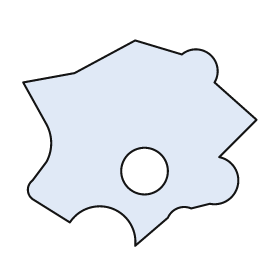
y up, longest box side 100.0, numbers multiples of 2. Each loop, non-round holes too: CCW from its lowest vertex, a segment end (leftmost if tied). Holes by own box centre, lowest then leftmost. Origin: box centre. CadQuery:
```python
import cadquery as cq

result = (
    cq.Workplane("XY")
    .moveTo(-2.0, -44.0)
    .lineTo(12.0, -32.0)
    .threePointArc((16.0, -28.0), (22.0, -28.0))
    .lineTo(30.0, -26.0)
    .threePointArc((42.0, -18.0), (34.0, -6.0))
    .lineTo(50.0, 10.0)
    .lineTo(32.0, 26.0)
    .threePointArc((30.0, 38.0), (18.0, 38.0))
    .lineTo(-2.0, 44.0)
    .lineTo(-28.0, 30.0)
    .lineTo(-50.0, 26.0)
    .lineTo(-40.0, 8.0)
    .threePointArc((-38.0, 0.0), (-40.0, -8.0))
    .lineTo(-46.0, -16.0)
    .threePointArc((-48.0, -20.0), (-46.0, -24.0))
    .lineTo(-30.0, -34.0)
    .threePointArc((-12.0, -28.0), (-2.0, -44.0))
    .close()
    .moveTo(2.0, -12.0)
    .circle(10.0)
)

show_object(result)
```